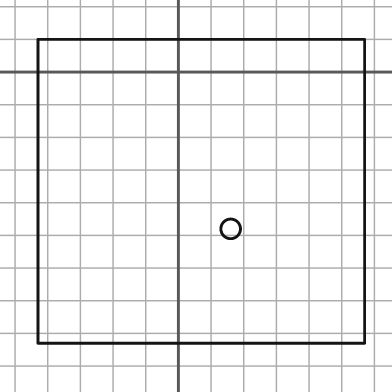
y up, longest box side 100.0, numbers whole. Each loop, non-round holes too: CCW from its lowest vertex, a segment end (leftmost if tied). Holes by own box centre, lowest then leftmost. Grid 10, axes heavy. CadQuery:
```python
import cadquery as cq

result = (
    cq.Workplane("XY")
    .moveTo(-43.0, -83.0)
    .lineTo(57.0, -83.0)
    .lineTo(57.0, 10.0)
    .lineTo(-43.0, 10.0)
    .close()
    .moveTo(16.0, -48.0)
    .circle(3.0)
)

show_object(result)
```